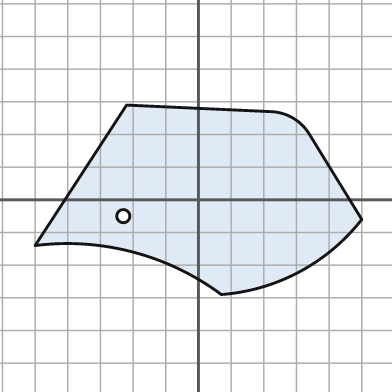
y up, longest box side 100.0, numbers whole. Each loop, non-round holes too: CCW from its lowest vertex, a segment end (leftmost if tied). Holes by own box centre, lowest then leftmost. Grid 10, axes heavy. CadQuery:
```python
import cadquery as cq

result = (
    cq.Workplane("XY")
    .moveTo(7.0, -29.0)
    .threePointArc((31.0, -22.0), (50.0, -6.0))
    .lineTo(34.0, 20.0)
    .threePointArc((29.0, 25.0), (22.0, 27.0))
    .lineTo(-22.0, 29.0)
    .lineTo(-50.0, -14.0)
    .threePointArc((-20.0, -16.0), (7.0, -29.0))
    .close()
    .moveTo(-23.0, -5.0)
    .circle(2.0)
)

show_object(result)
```